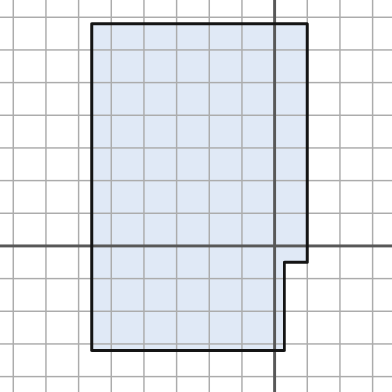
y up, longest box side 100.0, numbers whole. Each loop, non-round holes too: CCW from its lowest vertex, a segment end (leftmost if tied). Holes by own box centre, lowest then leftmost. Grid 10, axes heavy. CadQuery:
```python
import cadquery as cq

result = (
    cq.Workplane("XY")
    .moveTo(-56.0, -32.0)
    .lineTo(3.0, -32.0)
    .lineTo(3.0, -5.0)
    .lineTo(10.0, -5.0)
    .lineTo(10.0, 68.0)
    .lineTo(-56.0, 68.0)
    .close()
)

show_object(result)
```